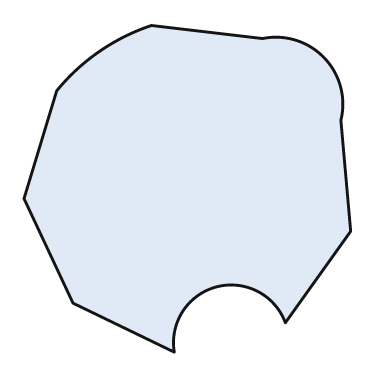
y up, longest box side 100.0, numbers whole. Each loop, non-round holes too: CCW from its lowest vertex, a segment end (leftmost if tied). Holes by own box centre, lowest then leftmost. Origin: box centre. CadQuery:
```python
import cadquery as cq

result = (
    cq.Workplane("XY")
    .moveTo(-4.0, -50.0)
    .threePointArc((9.0, -30.0), (30.0, -41.0))
    .lineTo(50.0, -13.0)
    .lineTo(47.0, 21.0)
    .threePointArc((42.0, 40.0), (23.0, 46.0))
    .lineTo(-11.0, 50.0)
    .threePointArc((-27.0, 42.0), (-40.0, 30.0))
    .lineTo(-50.0, -3.0)
    .lineTo(-35.0, -35.0)
    .close()
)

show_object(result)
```